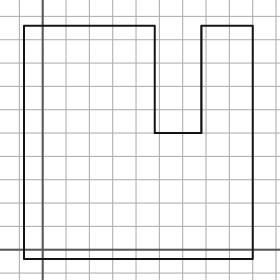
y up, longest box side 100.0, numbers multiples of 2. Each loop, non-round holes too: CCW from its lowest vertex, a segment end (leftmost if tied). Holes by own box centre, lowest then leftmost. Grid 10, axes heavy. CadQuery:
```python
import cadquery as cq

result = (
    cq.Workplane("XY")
    .moveTo(-8.0, -4.0)
    .lineTo(90.0, -4.0)
    .lineTo(90.0, 96.0)
    .lineTo(68.0, 96.0)
    .lineTo(68.0, 50.0)
    .lineTo(48.0, 50.0)
    .lineTo(48.0, 96.0)
    .lineTo(-8.0, 96.0)
    .close()
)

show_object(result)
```